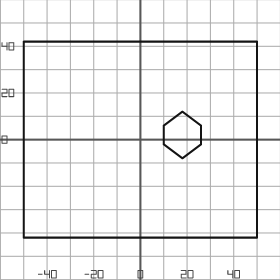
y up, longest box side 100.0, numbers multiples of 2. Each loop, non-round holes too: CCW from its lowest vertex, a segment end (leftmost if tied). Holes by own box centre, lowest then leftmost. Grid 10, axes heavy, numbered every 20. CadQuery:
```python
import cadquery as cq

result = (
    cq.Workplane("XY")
    .moveTo(-50.0, -42.0)
    .lineTo(50.0, -42.0)
    .lineTo(50.0, 42.0)
    .lineTo(-50.0, 42.0)
    .close()
    .moveTo(18.0, -8.0)
    .lineTo(26.0, -2.0)
    .lineTo(26.0, 6.0)
    .lineTo(18.0, 12.0)
    .lineTo(10.0, 6.0)
    .lineTo(10.0, -2.0)
    .close()
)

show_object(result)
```